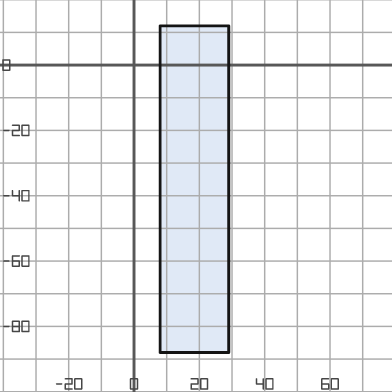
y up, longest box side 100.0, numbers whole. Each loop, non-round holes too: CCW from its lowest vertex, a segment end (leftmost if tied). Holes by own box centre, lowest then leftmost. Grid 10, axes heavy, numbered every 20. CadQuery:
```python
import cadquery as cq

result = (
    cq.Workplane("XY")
    .moveTo(8.0, -88.0)
    .lineTo(29.0, -88.0)
    .lineTo(29.0, 12.0)
    .lineTo(8.0, 12.0)
    .close()
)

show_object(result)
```